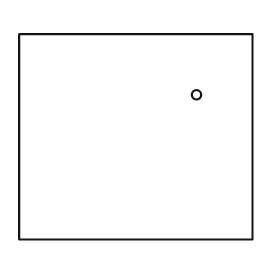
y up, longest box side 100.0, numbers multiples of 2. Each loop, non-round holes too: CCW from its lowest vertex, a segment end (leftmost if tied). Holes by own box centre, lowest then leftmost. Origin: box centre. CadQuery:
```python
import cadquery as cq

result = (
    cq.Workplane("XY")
    .moveTo(-50.0, -44.0)
    .lineTo(50.0, -44.0)
    .lineTo(50.0, 44.0)
    .lineTo(-50.0, 44.0)
    .close()
    .moveTo(26.0, 18.0)
    .circle(2.0)
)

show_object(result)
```